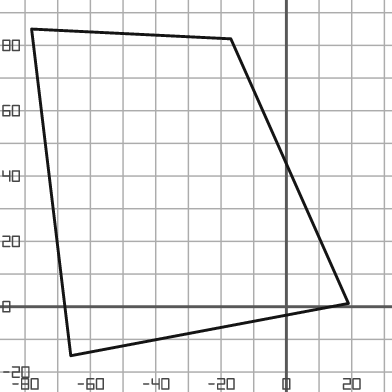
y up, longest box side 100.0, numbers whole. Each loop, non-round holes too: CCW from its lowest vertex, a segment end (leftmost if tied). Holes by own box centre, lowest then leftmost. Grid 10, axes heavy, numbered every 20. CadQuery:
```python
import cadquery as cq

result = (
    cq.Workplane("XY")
    .moveTo(-66.0, -15.0)
    .lineTo(19.0, 1.0)
    .lineTo(-17.0, 82.0)
    .lineTo(-78.0, 85.0)
    .close()
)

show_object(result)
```